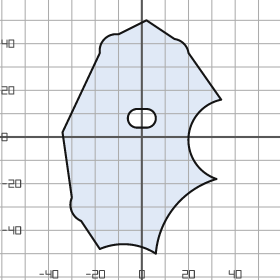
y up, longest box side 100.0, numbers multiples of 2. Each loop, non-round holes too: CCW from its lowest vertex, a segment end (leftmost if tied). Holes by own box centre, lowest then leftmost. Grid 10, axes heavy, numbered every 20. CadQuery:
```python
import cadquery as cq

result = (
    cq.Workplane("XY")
    .moveTo(6.0, -50.0)
    .threePointArc((14.0, -30.0), (32.0, -18.0))
    .threePointArc((20.0, 0.0), (34.0, 16.0))
    .lineTo(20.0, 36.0)
    .threePointArc((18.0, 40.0), (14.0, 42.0))
    .lineTo(2.0, 50.0)
    .lineTo(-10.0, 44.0)
    .threePointArc((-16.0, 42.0), (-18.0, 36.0))
    .lineTo(-34.0, 2.0)
    .lineTo(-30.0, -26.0)
    .threePointArc((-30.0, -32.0), (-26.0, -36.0))
    .lineTo(-18.0, -48.0)
    .threePointArc((-6.0, -46.0), (6.0, -50.0))
    .close()
    .moveTo(-2.0, 4.0)
    .lineTo(2.0, 4.0)
    .threePointArc((6.0, 8.0), (2.0, 12.0))
    .lineTo(-2.0, 12.0)
    .threePointArc((-6.0, 8.0), (-2.0, 4.0))
    .close()
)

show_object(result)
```